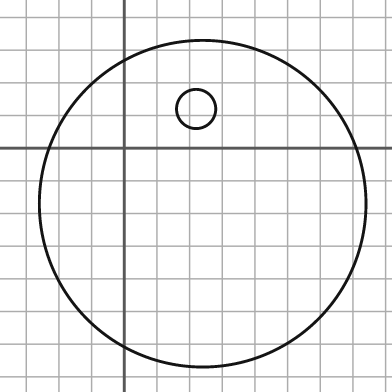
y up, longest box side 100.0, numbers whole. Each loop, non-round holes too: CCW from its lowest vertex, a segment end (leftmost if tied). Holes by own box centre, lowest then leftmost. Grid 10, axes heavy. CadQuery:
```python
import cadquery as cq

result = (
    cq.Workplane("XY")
    .moveTo(24.0, -17.0)
    .circle(50.0)
    .moveTo(22.0, 12.0)
    .circle(6.0)
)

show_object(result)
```